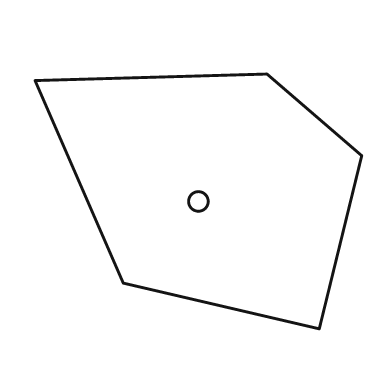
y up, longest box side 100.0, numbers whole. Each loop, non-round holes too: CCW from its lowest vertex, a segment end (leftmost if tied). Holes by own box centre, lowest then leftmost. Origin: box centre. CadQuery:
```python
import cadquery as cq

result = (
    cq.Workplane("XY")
    .moveTo(37.0, -39.0)
    .lineTo(50.0, 14.0)
    .lineTo(21.0, 39.0)
    .lineTo(-50.0, 37.0)
    .lineTo(-23.0, -25.0)
    .close()
    .moveTo(0.0, 0.0)
    .circle(3.0)
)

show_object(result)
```